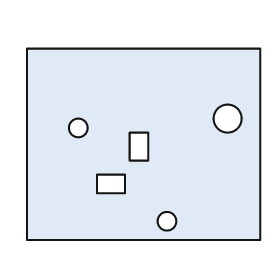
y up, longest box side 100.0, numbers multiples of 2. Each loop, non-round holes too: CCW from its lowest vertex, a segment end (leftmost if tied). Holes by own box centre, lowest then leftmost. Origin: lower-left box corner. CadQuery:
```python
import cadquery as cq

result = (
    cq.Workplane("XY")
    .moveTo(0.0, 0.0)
    .lineTo(100.0, 0.0)
    .lineTo(100.0, 82.0)
    .lineTo(0.0, 82.0)
    .close()
    .moveTo(60.0, 8.0)
    .circle(4.0)
    .moveTo(30.0, 20.0)
    .lineTo(42.0, 20.0)
    .lineTo(42.0, 28.0)
    .lineTo(30.0, 28.0)
    .close()
    .moveTo(44.0, 34.0)
    .lineTo(52.0, 34.0)
    .lineTo(52.0, 46.0)
    .lineTo(44.0, 46.0)
    .close()
    .moveTo(22.0, 48.0)
    .circle(4.0)
    .moveTo(86.0, 52.0)
    .circle(6.0)
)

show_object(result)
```